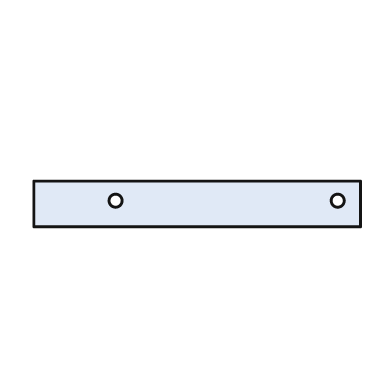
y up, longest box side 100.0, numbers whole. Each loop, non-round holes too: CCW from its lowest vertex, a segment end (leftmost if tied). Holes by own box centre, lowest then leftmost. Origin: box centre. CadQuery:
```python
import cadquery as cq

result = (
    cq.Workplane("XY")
    .moveTo(-50.0, -7.0)
    .lineTo(50.0, -7.0)
    .lineTo(50.0, 7.0)
    .lineTo(-50.0, 7.0)
    .close()
    .moveTo(-25.0, 1.0)
    .circle(2.0)
    .moveTo(43.0, 1.0)
    .circle(2.0)
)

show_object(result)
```